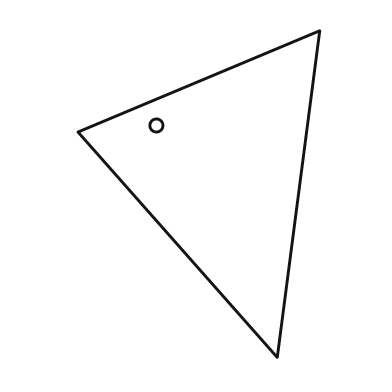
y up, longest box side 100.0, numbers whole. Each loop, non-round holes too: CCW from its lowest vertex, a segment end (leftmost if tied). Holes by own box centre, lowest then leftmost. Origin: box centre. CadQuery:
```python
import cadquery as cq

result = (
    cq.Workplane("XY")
    .moveTo(24.0, -50.0)
    .lineTo(37.0, 50.0)
    .lineTo(-37.0, 19.0)
    .close()
    .moveTo(-13.0, 21.0)
    .circle(2.0)
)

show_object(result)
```